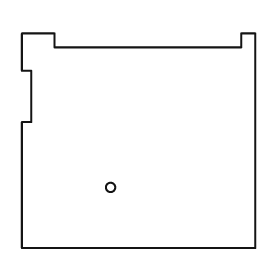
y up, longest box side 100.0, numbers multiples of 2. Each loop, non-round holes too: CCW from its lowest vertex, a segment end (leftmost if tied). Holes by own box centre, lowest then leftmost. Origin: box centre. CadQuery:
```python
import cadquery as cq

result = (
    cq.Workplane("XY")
    .moveTo(-50.0, -46.0)
    .lineTo(50.0, -46.0)
    .lineTo(50.0, 46.0)
    .lineTo(44.0, 46.0)
    .lineTo(44.0, 40.0)
    .lineTo(-36.0, 40.0)
    .lineTo(-36.0, 46.0)
    .lineTo(-50.0, 46.0)
    .lineTo(-50.0, 30.0)
    .lineTo(-46.0, 30.0)
    .lineTo(-46.0, 8.0)
    .lineTo(-50.0, 8.0)
    .close()
    .moveTo(-12.0, -20.0)
    .circle(2.0)
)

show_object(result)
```